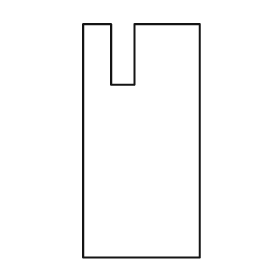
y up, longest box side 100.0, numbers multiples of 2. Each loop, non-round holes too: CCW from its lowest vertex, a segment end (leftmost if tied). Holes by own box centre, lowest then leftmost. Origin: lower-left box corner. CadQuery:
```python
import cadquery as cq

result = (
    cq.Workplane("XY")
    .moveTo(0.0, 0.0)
    .lineTo(50.0, 0.0)
    .lineTo(50.0, 100.0)
    .lineTo(22.0, 100.0)
    .lineTo(22.0, 74.0)
    .lineTo(12.0, 74.0)
    .lineTo(12.0, 100.0)
    .lineTo(0.0, 100.0)
    .close()
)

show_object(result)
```